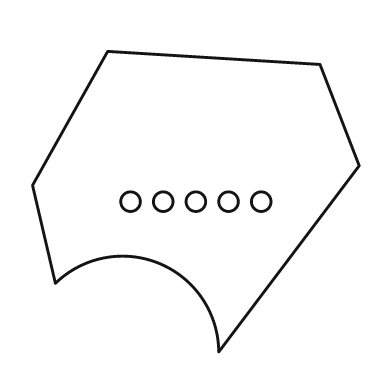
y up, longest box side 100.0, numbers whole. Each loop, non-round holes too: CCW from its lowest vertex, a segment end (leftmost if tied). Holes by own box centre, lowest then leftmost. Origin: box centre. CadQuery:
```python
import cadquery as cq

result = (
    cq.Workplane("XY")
    .moveTo(7.0, -46.0)
    .lineTo(50.0, 11.0)
    .lineTo(38.0, 42.0)
    .lineTo(-27.0, 46.0)
    .lineTo(-50.0, 5.0)
    .lineTo(-43.0, -25.0)
    .threePointArc((-11.0, -19.0), (7.0, -46.0))
    .close()
    .moveTo(-20.0, 0.0)
    .circle(3.0)
    .moveTo(-10.0, 0.0)
    .circle(3.0)
    .moveTo(0.0, 0.0)
    .circle(3.0)
    .moveTo(10.0, 0.0)
    .circle(3.0)
    .moveTo(20.0, 0.0)
    .circle(3.0)
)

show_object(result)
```